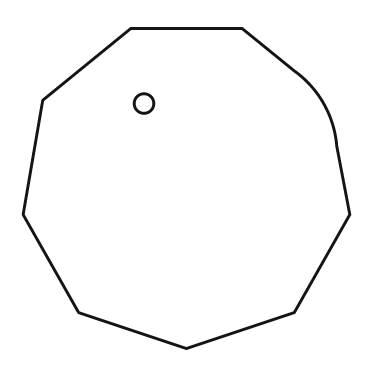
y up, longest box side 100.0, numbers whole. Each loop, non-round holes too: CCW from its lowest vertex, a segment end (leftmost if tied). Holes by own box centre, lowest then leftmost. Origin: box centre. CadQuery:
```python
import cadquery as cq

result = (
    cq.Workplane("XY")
    .moveTo(0.0, -49.0)
    .lineTo(33.0, -38.0)
    .lineTo(50.0, -8.0)
    .lineTo(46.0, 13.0)
    .threePointArc((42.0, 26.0), (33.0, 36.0))
    .lineTo(17.0, 49.0)
    .lineTo(-17.0, 49.0)
    .lineTo(-44.0, 27.0)
    .lineTo(-50.0, -8.0)
    .lineTo(-33.0, -38.0)
    .close()
    .moveTo(-13.0, 26.0)
    .circle(3.0)
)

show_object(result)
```